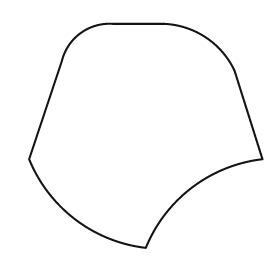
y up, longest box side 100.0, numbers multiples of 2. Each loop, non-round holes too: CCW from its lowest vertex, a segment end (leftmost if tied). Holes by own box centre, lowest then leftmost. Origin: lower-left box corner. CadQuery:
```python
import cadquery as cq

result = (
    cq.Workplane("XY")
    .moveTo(50.0, 0.0)
    .threePointArc((70.0, 26.0), (100.0, 38.0))
    .lineTo(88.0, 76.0)
    .threePointArc((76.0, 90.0), (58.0, 96.0))
    .lineTo(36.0, 96.0)
    .threePointArc((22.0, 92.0), (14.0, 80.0))
    .lineTo(0.0, 38.0)
    .threePointArc((20.0, 12.0), (50.0, 0.0))
    .close()
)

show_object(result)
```